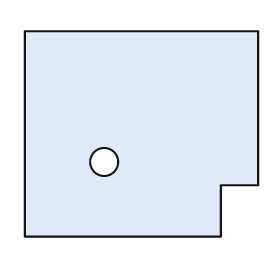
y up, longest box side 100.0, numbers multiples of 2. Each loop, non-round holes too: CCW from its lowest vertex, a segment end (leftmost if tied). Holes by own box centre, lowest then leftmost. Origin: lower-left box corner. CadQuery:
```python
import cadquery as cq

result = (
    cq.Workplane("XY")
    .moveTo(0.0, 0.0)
    .lineTo(84.0, 0.0)
    .lineTo(84.0, 22.0)
    .lineTo(100.0, 22.0)
    .lineTo(100.0, 88.0)
    .lineTo(0.0, 88.0)
    .close()
    .moveTo(34.0, 32.0)
    .circle(6.0)
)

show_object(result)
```